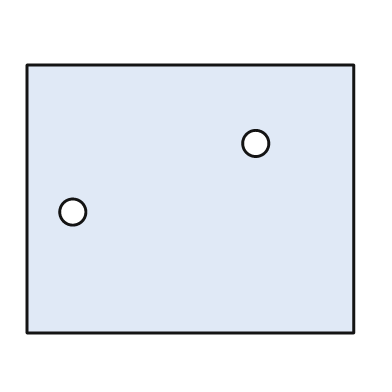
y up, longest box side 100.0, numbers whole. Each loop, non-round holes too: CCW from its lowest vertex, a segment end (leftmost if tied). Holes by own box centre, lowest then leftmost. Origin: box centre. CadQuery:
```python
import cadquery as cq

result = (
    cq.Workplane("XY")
    .moveTo(-50.0, -41.0)
    .lineTo(50.0, -41.0)
    .lineTo(50.0, 41.0)
    .lineTo(-50.0, 41.0)
    .close()
    .moveTo(-36.0, -4.0)
    .circle(4.0)
    .moveTo(20.0, 17.0)
    .circle(4.0)
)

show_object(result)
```